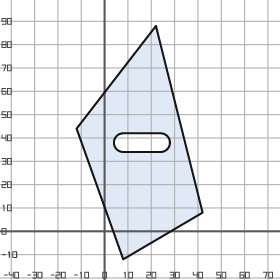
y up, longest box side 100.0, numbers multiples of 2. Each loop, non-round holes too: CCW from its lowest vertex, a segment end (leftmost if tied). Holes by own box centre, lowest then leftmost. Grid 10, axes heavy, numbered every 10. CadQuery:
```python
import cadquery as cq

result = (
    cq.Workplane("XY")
    .moveTo(8.0, -12.0)
    .lineTo(42.0, 8.0)
    .lineTo(22.0, 88.0)
    .lineTo(-12.0, 44.0)
    .close()
    .moveTo(8.0, 34.0)
    .lineTo(24.0, 34.0)
    .threePointArc((28.0, 38.0), (24.0, 42.0))
    .lineTo(8.0, 42.0)
    .threePointArc((4.0, 38.0), (8.0, 34.0))
    .close()
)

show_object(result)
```